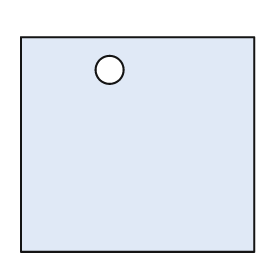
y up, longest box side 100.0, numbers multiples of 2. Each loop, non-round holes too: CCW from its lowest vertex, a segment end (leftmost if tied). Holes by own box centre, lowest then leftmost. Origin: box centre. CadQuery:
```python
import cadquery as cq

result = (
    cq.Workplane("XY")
    .moveTo(-50.0, -46.0)
    .lineTo(50.0, -46.0)
    .lineTo(50.0, 46.0)
    .lineTo(-50.0, 46.0)
    .close()
    .moveTo(-12.0, 32.0)
    .circle(6.0)
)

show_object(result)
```